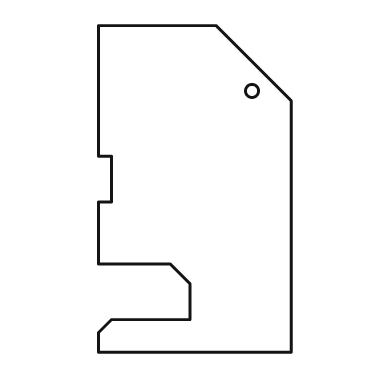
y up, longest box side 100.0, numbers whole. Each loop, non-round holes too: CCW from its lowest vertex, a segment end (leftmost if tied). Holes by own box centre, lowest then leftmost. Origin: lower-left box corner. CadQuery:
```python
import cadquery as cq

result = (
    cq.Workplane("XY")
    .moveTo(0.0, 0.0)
    .lineTo(59.0, 0.0)
    .lineTo(59.0, 77.0)
    .lineTo(36.0, 100.0)
    .lineTo(0.0, 100.0)
    .lineTo(0.0, 60.0)
    .lineTo(4.0, 60.0)
    .lineTo(4.0, 46.0)
    .lineTo(0.0, 46.0)
    .lineTo(0.0, 27.0)
    .lineTo(22.0, 27.0)
    .lineTo(28.0, 21.0)
    .lineTo(28.0, 10.0)
    .lineTo(4.0, 10.0)
    .lineTo(0.0, 6.0)
    .close()
    .moveTo(47.0, 80.0)
    .circle(2.0)
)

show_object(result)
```